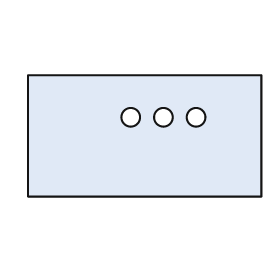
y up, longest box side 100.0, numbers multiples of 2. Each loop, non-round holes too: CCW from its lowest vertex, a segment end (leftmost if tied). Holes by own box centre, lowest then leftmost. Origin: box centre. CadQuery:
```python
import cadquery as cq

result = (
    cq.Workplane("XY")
    .moveTo(-50.0, -26.0)
    .lineTo(50.0, -26.0)
    .lineTo(50.0, 26.0)
    .lineTo(-50.0, 26.0)
    .close()
    .moveTo(-6.0, 8.0)
    .circle(4.0)
    .moveTo(8.0, 8.0)
    .circle(4.0)
    .moveTo(22.0, 8.0)
    .circle(4.0)
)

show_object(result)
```